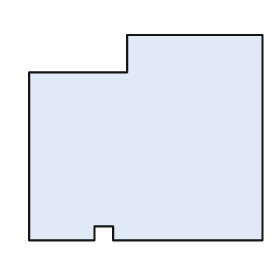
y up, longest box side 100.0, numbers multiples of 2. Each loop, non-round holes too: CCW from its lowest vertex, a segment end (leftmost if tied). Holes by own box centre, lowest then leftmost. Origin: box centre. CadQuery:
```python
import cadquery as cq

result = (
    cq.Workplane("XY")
    .moveTo(-50.0, -44.0)
    .lineTo(-22.0, -44.0)
    .lineTo(-22.0, -38.0)
    .lineTo(-14.0, -38.0)
    .lineTo(-14.0, -44.0)
    .lineTo(50.0, -44.0)
    .lineTo(50.0, 44.0)
    .lineTo(-8.0, 44.0)
    .lineTo(-8.0, 28.0)
    .lineTo(-50.0, 28.0)
    .close()
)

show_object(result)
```